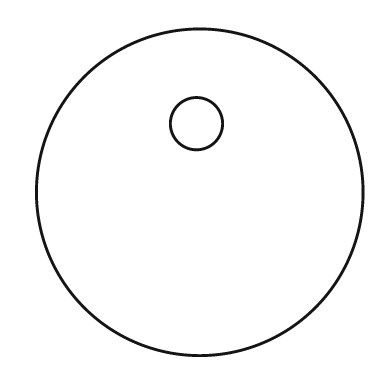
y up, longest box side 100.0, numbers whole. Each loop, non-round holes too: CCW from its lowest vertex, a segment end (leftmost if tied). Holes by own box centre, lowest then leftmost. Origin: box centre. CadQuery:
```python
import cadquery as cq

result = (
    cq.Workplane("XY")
    .moveTo(0.0, 0.0)
    .circle(50.0)
    .moveTo(-1.0, 21.0)
    .circle(8.0)
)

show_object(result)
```